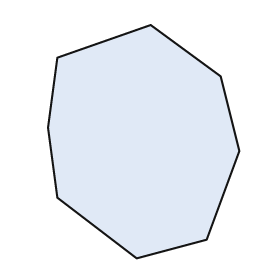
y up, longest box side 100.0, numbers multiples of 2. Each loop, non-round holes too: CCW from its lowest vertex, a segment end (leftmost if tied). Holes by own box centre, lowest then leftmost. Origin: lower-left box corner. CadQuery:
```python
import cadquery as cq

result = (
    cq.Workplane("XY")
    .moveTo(38.0, 0.0)
    .lineTo(68.0, 8.0)
    .lineTo(82.0, 46.0)
    .lineTo(74.0, 78.0)
    .lineTo(44.0, 100.0)
    .lineTo(4.0, 86.0)
    .lineTo(0.0, 56.0)
    .lineTo(4.0, 26.0)
    .close()
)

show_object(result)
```